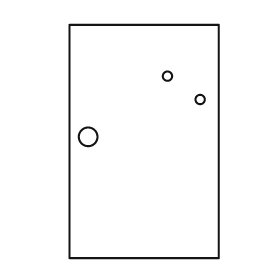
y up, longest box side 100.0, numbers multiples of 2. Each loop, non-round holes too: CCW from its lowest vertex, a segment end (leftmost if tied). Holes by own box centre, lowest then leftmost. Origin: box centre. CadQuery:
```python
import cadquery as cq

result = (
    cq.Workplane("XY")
    .moveTo(-32.0, -50.0)
    .lineTo(32.0, -50.0)
    .lineTo(32.0, 50.0)
    .lineTo(-32.0, 50.0)
    .close()
    .moveTo(-24.0, 2.0)
    .circle(4.0)
    .moveTo(24.0, 18.0)
    .circle(2.0)
    .moveTo(10.0, 28.0)
    .circle(2.0)
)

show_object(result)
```